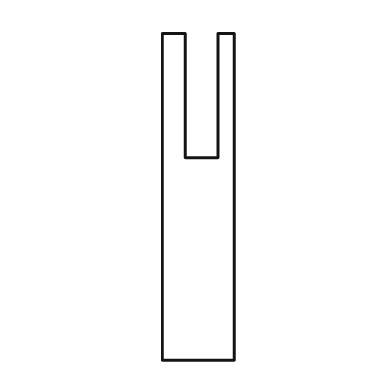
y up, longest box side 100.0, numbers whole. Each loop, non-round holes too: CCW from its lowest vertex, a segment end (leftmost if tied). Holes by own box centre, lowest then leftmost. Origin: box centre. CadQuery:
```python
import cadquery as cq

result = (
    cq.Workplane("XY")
    .moveTo(-11.0, -50.0)
    .lineTo(11.0, -50.0)
    .lineTo(11.0, 50.0)
    .lineTo(6.0, 50.0)
    .lineTo(6.0, 12.0)
    .lineTo(-4.0, 12.0)
    .lineTo(-4.0, 50.0)
    .lineTo(-11.0, 50.0)
    .close()
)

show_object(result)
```